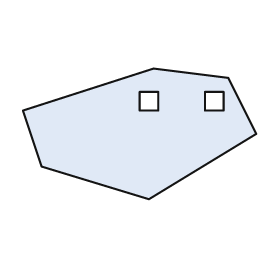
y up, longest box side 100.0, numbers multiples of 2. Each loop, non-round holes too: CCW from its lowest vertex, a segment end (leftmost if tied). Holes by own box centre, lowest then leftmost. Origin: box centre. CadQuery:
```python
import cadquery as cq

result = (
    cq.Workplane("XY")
    .moveTo(4.0, -28.0)
    .lineTo(50.0, 0.0)
    .lineTo(38.0, 24.0)
    .lineTo(6.0, 28.0)
    .lineTo(-50.0, 10.0)
    .lineTo(-42.0, -14.0)
    .close()
    .moveTo(0.0, 10.0)
    .lineTo(8.0, 10.0)
    .lineTo(8.0, 18.0)
    .lineTo(0.0, 18.0)
    .close()
    .moveTo(28.0, 10.0)
    .lineTo(36.0, 10.0)
    .lineTo(36.0, 18.0)
    .lineTo(28.0, 18.0)
    .close()
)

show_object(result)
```